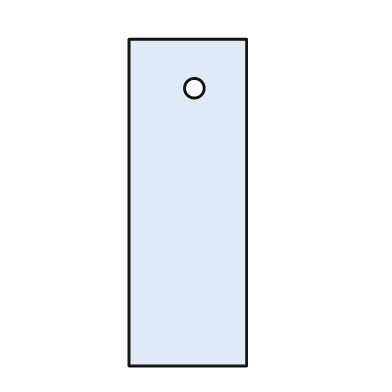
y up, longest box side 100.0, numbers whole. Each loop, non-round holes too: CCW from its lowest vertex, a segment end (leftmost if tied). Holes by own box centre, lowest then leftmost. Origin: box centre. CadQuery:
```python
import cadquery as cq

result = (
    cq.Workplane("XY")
    .moveTo(-18.0, -50.0)
    .lineTo(18.0, -50.0)
    .lineTo(18.0, 50.0)
    .lineTo(-18.0, 50.0)
    .close()
    .moveTo(2.0, 35.0)
    .circle(3.0)
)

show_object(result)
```